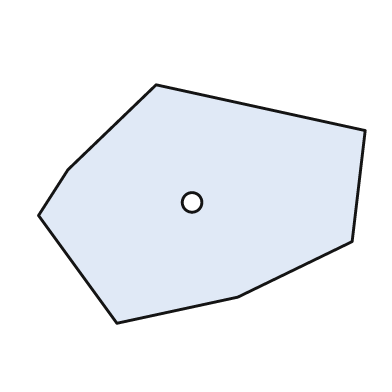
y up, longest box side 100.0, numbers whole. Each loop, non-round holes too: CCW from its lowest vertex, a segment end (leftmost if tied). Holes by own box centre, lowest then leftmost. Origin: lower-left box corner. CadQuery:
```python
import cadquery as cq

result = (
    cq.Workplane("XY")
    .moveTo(24.0, 0.0)
    .lineTo(61.0, 8.0)
    .lineTo(96.0, 25.0)
    .lineTo(100.0, 59.0)
    .lineTo(36.0, 73.0)
    .lineTo(9.0, 47.0)
    .lineTo(0.0, 33.0)
    .close()
    .moveTo(47.0, 37.0)
    .circle(3.0)
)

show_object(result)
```